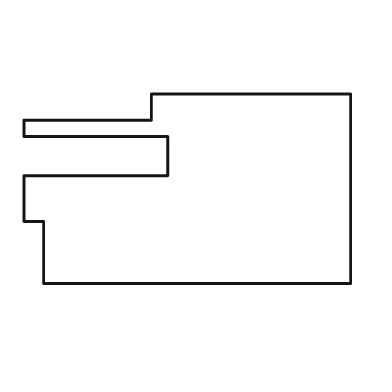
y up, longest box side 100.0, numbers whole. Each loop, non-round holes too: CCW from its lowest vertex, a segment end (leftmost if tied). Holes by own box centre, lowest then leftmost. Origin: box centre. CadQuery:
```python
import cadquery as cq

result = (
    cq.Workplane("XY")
    .moveTo(-44.0, -29.0)
    .lineTo(50.0, -29.0)
    .lineTo(50.0, 29.0)
    .lineTo(-11.0, 29.0)
    .lineTo(-11.0, 21.0)
    .lineTo(-50.0, 21.0)
    .lineTo(-50.0, 16.0)
    .lineTo(-6.0, 16.0)
    .lineTo(-6.0, 4.0)
    .lineTo(-50.0, 4.0)
    .lineTo(-50.0, -10.0)
    .lineTo(-44.0, -10.0)
    .close()
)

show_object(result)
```